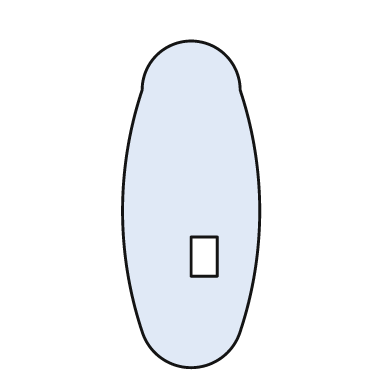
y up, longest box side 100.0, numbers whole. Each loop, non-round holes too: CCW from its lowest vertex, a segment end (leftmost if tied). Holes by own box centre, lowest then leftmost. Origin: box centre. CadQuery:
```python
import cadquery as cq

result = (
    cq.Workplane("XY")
    .moveTo(-15.0, -39.0)
    .threePointArc((0.0, -50.0), (15.0, -39.0))
    .threePointArc((21.0, -2.0), (15.0, 35.0))
    .threePointArc((0.0, 50.0), (-15.0, 35.0))
    .threePointArc((-21.0, -2.0), (-15.0, -39.0))
    .close()
    .moveTo(0.0, -22.0)
    .lineTo(8.0, -22.0)
    .lineTo(8.0, -10.0)
    .lineTo(0.0, -10.0)
    .close()
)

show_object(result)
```